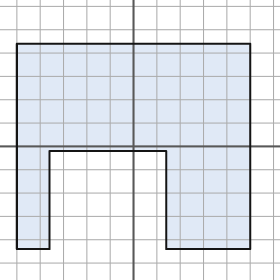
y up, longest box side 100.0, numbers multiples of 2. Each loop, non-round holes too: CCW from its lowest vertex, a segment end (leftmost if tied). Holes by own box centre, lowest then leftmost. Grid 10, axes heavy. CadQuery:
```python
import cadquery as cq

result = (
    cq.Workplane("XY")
    .moveTo(-50.0, -44.0)
    .lineTo(-36.0, -44.0)
    .lineTo(-36.0, -2.0)
    .lineTo(14.0, -2.0)
    .lineTo(14.0, -44.0)
    .lineTo(50.0, -44.0)
    .lineTo(50.0, 44.0)
    .lineTo(-50.0, 44.0)
    .close()
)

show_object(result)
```